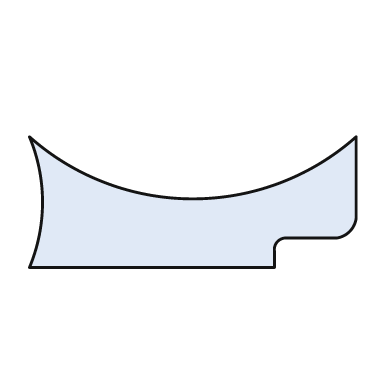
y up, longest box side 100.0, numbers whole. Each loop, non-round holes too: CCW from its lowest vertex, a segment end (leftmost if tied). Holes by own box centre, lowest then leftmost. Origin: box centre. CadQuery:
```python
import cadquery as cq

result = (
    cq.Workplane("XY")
    .moveTo(-50.0, -20.0)
    .lineTo(25.0, -20.0)
    .lineTo(25.0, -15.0)
    .threePointArc((26.0, -12.0), (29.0, -11.0))
    .lineTo(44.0, -11.0)
    .threePointArc((48.0, -9.0), (50.0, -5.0))
    .lineTo(50.0, 20.0)
    .threePointArc((0.0, 1.0), (-50.0, 20.0))
    .threePointArc((-46.0, 0.0), (-50.0, -20.0))
    .close()
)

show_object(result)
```